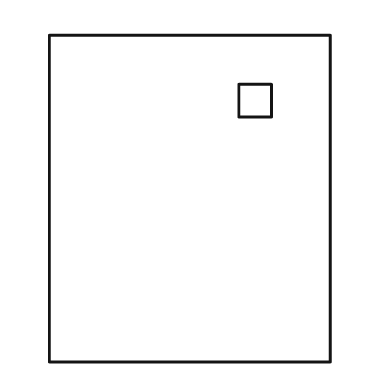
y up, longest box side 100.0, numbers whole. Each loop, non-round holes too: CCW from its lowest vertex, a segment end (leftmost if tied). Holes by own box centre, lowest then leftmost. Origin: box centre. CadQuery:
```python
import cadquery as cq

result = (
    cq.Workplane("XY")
    .moveTo(-43.0, -50.0)
    .lineTo(43.0, -50.0)
    .lineTo(43.0, 50.0)
    .lineTo(-43.0, 50.0)
    .close()
    .moveTo(15.0, 25.0)
    .lineTo(25.0, 25.0)
    .lineTo(25.0, 35.0)
    .lineTo(15.0, 35.0)
    .close()
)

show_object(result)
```